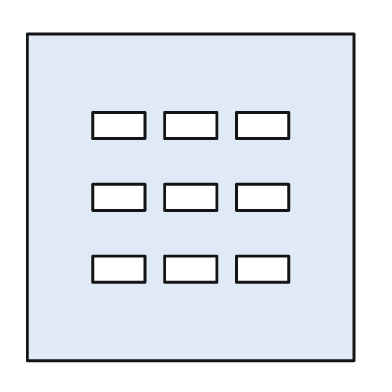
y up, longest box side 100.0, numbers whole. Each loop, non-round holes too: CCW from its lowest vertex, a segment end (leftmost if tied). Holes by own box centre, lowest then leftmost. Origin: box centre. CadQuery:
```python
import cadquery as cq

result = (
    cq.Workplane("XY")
    .moveTo(-50.0, -50.0)
    .lineTo(50.0, -50.0)
    .lineTo(50.0, 50.0)
    .lineTo(-50.0, 50.0)
    .close()
    .moveTo(-30.0, -26.0)
    .lineTo(-14.0, -26.0)
    .lineTo(-14.0, -18.0)
    .lineTo(-30.0, -18.0)
    .close()
    .moveTo(-8.0, -26.0)
    .lineTo(8.0, -26.0)
    .lineTo(8.0, -18.0)
    .lineTo(-8.0, -18.0)
    .close()
    .moveTo(14.0, -26.0)
    .lineTo(30.0, -26.0)
    .lineTo(30.0, -18.0)
    .lineTo(14.0, -18.0)
    .close()
    .moveTo(-30.0, -4.0)
    .lineTo(-14.0, -4.0)
    .lineTo(-14.0, 4.0)
    .lineTo(-30.0, 4.0)
    .close()
    .moveTo(-8.0, -4.0)
    .lineTo(8.0, -4.0)
    .lineTo(8.0, 4.0)
    .lineTo(-8.0, 4.0)
    .close()
    .moveTo(14.0, -4.0)
    .lineTo(30.0, -4.0)
    .lineTo(30.0, 4.0)
    .lineTo(14.0, 4.0)
    .close()
    .moveTo(-30.0, 18.0)
    .lineTo(-14.0, 18.0)
    .lineTo(-14.0, 26.0)
    .lineTo(-30.0, 26.0)
    .close()
    .moveTo(-8.0, 18.0)
    .lineTo(8.0, 18.0)
    .lineTo(8.0, 26.0)
    .lineTo(-8.0, 26.0)
    .close()
    .moveTo(14.0, 18.0)
    .lineTo(30.0, 18.0)
    .lineTo(30.0, 26.0)
    .lineTo(14.0, 26.0)
    .close()
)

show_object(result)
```